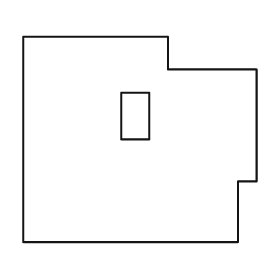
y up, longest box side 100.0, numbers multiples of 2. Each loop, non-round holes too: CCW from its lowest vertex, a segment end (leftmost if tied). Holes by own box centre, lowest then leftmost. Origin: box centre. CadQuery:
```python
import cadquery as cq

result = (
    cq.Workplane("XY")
    .moveTo(-50.0, -44.0)
    .lineTo(42.0, -44.0)
    .lineTo(42.0, -18.0)
    .lineTo(50.0, -18.0)
    .lineTo(50.0, 30.0)
    .lineTo(12.0, 30.0)
    .lineTo(12.0, 44.0)
    .lineTo(-50.0, 44.0)
    .close()
    .moveTo(-8.0, 0.0)
    .lineTo(4.0, 0.0)
    .lineTo(4.0, 20.0)
    .lineTo(-8.0, 20.0)
    .close()
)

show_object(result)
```